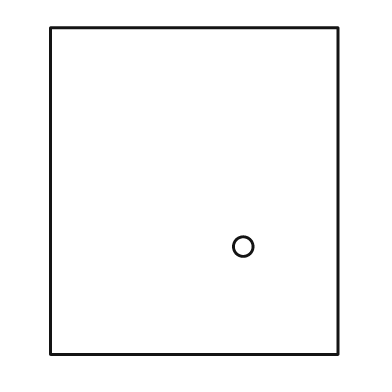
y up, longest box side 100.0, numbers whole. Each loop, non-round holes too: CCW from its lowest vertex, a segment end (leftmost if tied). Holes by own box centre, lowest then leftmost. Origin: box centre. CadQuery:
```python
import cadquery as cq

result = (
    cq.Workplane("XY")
    .moveTo(-44.0, -50.0)
    .lineTo(44.0, -50.0)
    .lineTo(44.0, 50.0)
    .lineTo(-44.0, 50.0)
    .close()
    .moveTo(15.0, -17.0)
    .circle(3.0)
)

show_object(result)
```